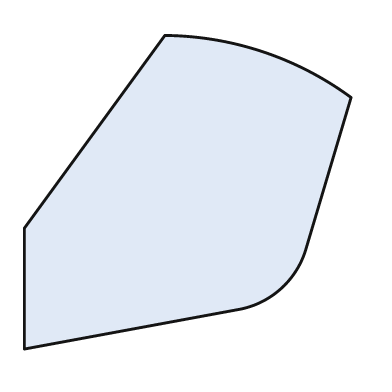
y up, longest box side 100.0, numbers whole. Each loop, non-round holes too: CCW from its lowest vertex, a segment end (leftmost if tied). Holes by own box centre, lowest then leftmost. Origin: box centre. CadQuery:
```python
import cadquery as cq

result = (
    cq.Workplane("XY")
    .moveTo(-50.0, -48.0)
    .lineTo(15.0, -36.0)
    .threePointArc((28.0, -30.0), (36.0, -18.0))
    .lineTo(50.0, 29.0)
    .threePointArc((23.0, 43.0), (-7.0, 48.0))
    .lineTo(-50.0, -11.0)
    .close()
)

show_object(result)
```